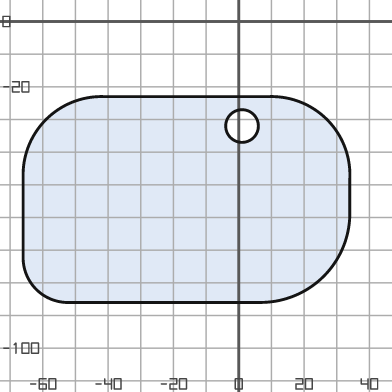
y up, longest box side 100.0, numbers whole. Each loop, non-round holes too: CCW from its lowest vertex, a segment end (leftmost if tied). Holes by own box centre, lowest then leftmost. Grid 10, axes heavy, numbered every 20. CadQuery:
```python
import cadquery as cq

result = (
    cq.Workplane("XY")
    .moveTo(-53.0, -86.0)
    .lineTo(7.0, -86.0)
    .threePointArc((26.0, -78.0), (34.0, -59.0))
    .lineTo(34.0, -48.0)
    .threePointArc((27.0, -30.0), (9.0, -23.0))
    .lineTo(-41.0, -23.0)
    .threePointArc((-59.0, -30.0), (-66.0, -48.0))
    .lineTo(-66.0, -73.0)
    .threePointArc((-62.0, -82.0), (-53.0, -86.0))
    .close()
    .moveTo(1.0, -32.0)
    .circle(5.0)
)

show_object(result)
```